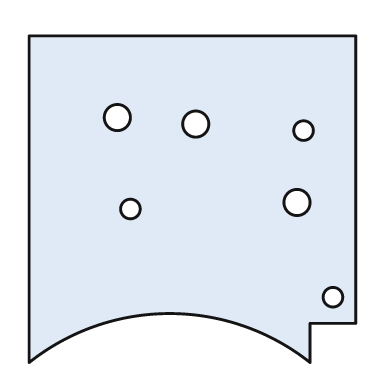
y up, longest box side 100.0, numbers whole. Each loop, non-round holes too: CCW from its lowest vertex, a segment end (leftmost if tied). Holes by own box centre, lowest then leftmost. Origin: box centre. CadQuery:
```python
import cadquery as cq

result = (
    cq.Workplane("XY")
    .moveTo(-50.0, -50.0)
    .threePointArc((-7.0, -35.0), (36.0, -50.0))
    .lineTo(36.0, -38.0)
    .lineTo(50.0, -38.0)
    .lineTo(50.0, 50.0)
    .lineTo(-50.0, 50.0)
    .close()
    .moveTo(43.0, -30.0)
    .circle(3.0)
    .moveTo(-19.0, -3.0)
    .circle(3.0)
    .moveTo(32.0, -1.0)
    .circle(4.0)
    .moveTo(34.0, 21.0)
    .circle(3.0)
    .moveTo(1.0, 23.0)
    .circle(4.0)
    .moveTo(-23.0, 25.0)
    .circle(4.0)
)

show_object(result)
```